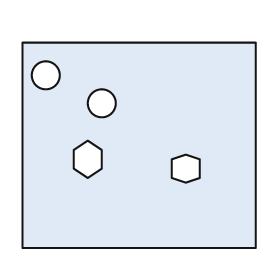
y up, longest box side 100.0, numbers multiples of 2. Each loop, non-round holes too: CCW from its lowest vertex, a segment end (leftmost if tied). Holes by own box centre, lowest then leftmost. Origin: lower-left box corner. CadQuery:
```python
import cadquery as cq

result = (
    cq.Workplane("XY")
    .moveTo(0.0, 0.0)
    .lineTo(100.0, 0.0)
    .lineTo(100.0, 88.0)
    .lineTo(0.0, 88.0)
    .close()
    .moveTo(70.0, 28.0)
    .lineTo(76.0, 30.0)
    .lineTo(76.0, 38.0)
    .lineTo(70.0, 40.0)
    .lineTo(64.0, 38.0)
    .lineTo(64.0, 30.0)
    .close()
    .moveTo(28.0, 30.0)
    .lineTo(34.0, 34.0)
    .lineTo(34.0, 42.0)
    .lineTo(28.0, 46.0)
    .lineTo(22.0, 42.0)
    .lineTo(22.0, 34.0)
    .close()
    .moveTo(34.0, 62.0)
    .circle(6.0)
    .moveTo(10.0, 74.0)
    .circle(6.0)
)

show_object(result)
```